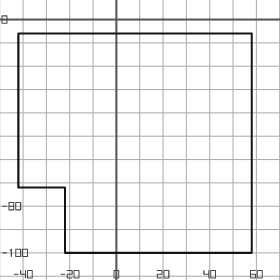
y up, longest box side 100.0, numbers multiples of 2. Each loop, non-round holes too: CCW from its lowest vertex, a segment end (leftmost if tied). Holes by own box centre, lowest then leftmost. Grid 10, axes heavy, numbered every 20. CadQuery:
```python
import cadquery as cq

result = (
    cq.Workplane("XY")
    .moveTo(-22.0, -100.0)
    .lineTo(58.0, -100.0)
    .lineTo(58.0, -6.0)
    .lineTo(-42.0, -6.0)
    .lineTo(-42.0, -72.0)
    .lineTo(-22.0, -72.0)
    .close()
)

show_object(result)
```